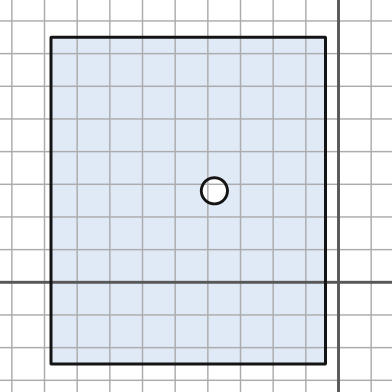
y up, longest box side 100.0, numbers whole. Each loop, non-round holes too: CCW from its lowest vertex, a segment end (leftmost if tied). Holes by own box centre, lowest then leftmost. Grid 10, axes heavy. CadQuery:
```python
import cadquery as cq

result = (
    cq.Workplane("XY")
    .moveTo(-88.0, -25.0)
    .lineTo(-4.0, -25.0)
    .lineTo(-4.0, 75.0)
    .lineTo(-88.0, 75.0)
    .close()
    .moveTo(-38.0, 28.0)
    .circle(4.0)
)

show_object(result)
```